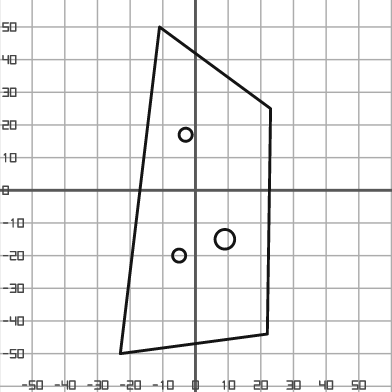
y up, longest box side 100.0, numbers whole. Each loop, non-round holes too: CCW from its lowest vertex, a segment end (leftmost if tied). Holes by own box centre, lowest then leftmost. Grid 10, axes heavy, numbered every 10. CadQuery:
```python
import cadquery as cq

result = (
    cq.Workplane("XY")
    .moveTo(-23.0, -50.0)
    .lineTo(22.0, -44.0)
    .lineTo(23.0, 25.0)
    .lineTo(-11.0, 50.0)
    .close()
    .moveTo(-5.0, -20.0)
    .circle(2.0)
    .moveTo(9.0, -15.0)
    .circle(3.0)
    .moveTo(-3.0, 17.0)
    .circle(2.0)
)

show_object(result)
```